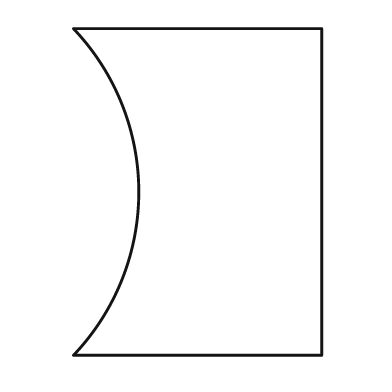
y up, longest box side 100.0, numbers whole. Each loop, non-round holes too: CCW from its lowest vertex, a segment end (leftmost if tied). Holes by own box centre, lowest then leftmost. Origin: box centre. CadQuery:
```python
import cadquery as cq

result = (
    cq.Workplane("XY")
    .moveTo(-38.0, -50.0)
    .lineTo(38.0, -50.0)
    .lineTo(38.0, 50.0)
    .lineTo(-38.0, 50.0)
    .threePointArc((-18.0, 0.0), (-38.0, -50.0))
    .close()
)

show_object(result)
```